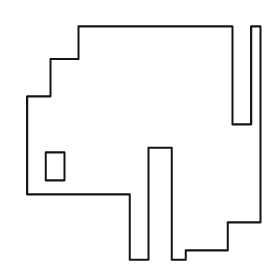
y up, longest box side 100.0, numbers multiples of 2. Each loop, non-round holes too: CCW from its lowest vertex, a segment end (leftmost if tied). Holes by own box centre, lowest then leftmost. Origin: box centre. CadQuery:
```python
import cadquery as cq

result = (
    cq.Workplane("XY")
    .moveTo(-6.0, -50.0)
    .lineTo(2.0, -50.0)
    .lineTo(2.0, -2.0)
    .lineTo(12.0, -2.0)
    .lineTo(12.0, -50.0)
    .lineTo(18.0, -50.0)
    .lineTo(18.0, -46.0)
    .lineTo(36.0, -46.0)
    .lineTo(36.0, -34.0)
    .lineTo(50.0, -34.0)
    .lineTo(50.0, 50.0)
    .lineTo(46.0, 50.0)
    .lineTo(46.0, 8.0)
    .lineTo(38.0, 8.0)
    .lineTo(38.0, 50.0)
    .lineTo(-28.0, 50.0)
    .lineTo(-28.0, 36.0)
    .lineTo(-40.0, 36.0)
    .lineTo(-40.0, 20.0)
    .lineTo(-50.0, 20.0)
    .lineTo(-50.0, -22.0)
    .lineTo(-6.0, -22.0)
    .close()
    .moveTo(-42.0, -16.0)
    .lineTo(-34.0, -16.0)
    .lineTo(-34.0, -4.0)
    .lineTo(-42.0, -4.0)
    .close()
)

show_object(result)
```